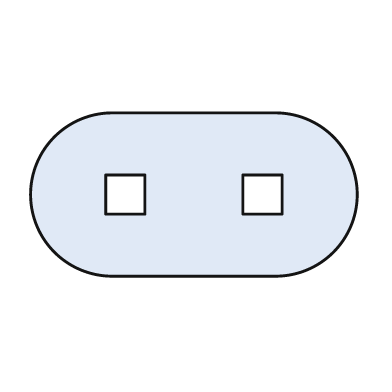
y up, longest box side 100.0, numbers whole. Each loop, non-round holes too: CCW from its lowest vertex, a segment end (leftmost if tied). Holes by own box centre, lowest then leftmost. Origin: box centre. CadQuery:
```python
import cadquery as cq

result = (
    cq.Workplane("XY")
    .moveTo(-25.0, -25.0)
    .lineTo(25.0, -25.0)
    .threePointArc((50.0, 0.0), (25.0, 25.0))
    .lineTo(-25.0, 25.0)
    .threePointArc((-50.0, 0.0), (-25.0, -25.0))
    .close()
    .moveTo(-27.0, -6.0)
    .lineTo(-15.0, -6.0)
    .lineTo(-15.0, 6.0)
    .lineTo(-27.0, 6.0)
    .close()
    .moveTo(15.0, -6.0)
    .lineTo(27.0, -6.0)
    .lineTo(27.0, 6.0)
    .lineTo(15.0, 6.0)
    .close()
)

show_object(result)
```